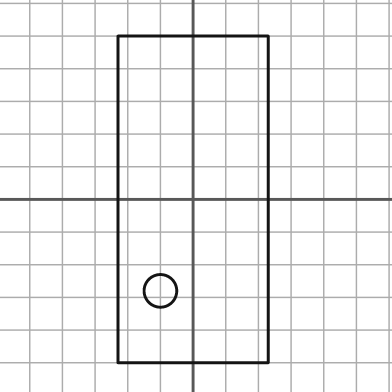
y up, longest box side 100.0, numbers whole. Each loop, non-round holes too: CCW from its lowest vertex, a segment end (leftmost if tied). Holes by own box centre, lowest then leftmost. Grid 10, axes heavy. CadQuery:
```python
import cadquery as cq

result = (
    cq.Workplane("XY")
    .moveTo(-23.0, -50.0)
    .lineTo(23.0, -50.0)
    .lineTo(23.0, 50.0)
    .lineTo(-23.0, 50.0)
    .close()
    .moveTo(-10.0, -28.0)
    .circle(5.0)
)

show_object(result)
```